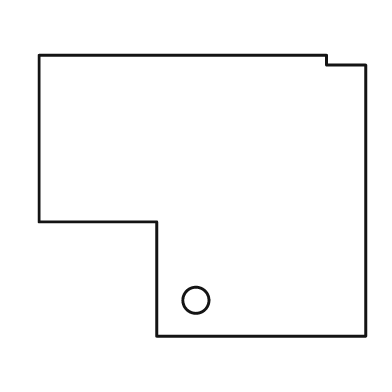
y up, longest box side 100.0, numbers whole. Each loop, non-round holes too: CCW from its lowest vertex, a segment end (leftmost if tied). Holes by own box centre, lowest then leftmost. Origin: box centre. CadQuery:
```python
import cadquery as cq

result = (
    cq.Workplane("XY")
    .moveTo(-14.0, -43.0)
    .lineTo(50.0, -43.0)
    .lineTo(50.0, 40.0)
    .lineTo(38.0, 40.0)
    .lineTo(38.0, 43.0)
    .lineTo(-50.0, 43.0)
    .lineTo(-50.0, -8.0)
    .lineTo(-14.0, -8.0)
    .close()
    .moveTo(-2.0, -32.0)
    .circle(4.0)
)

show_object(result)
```